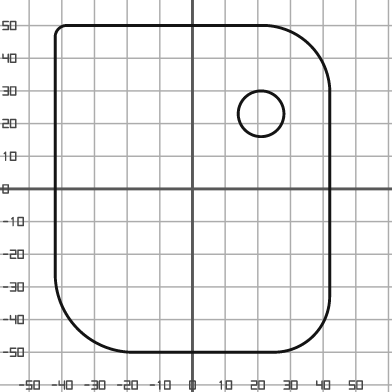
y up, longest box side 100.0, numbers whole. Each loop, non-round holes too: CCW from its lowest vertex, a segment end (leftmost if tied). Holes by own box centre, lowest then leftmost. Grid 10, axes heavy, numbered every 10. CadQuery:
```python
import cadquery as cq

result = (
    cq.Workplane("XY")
    .moveTo(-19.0, -50.0)
    .lineTo(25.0, -50.0)
    .threePointArc((37.0, -45.0), (42.0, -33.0))
    .lineTo(42.0, 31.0)
    .threePointArc((36.0, 44.0), (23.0, 50.0))
    .lineTo(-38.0, 50.0)
    .threePointArc((-41.0, 49.0), (-42.0, 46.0))
    .lineTo(-42.0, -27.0)
    .threePointArc((-35.0, -43.0), (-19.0, -50.0))
    .close()
    .moveTo(21.0, 23.0)
    .circle(7.0)
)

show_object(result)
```